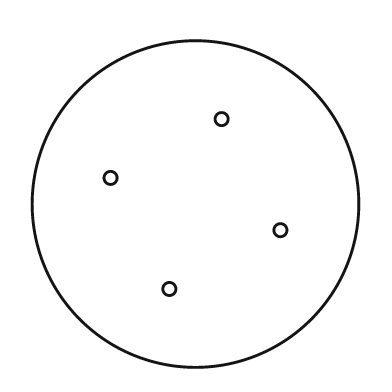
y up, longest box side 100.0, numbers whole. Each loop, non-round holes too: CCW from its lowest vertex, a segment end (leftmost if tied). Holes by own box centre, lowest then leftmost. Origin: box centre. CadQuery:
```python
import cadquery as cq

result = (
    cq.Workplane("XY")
    .moveTo(0.0, 0.0)
    .circle(50.0)
    .moveTo(-8.0, -26.0)
    .circle(2.0)
    .moveTo(26.0, -8.0)
    .circle(2.0)
    .moveTo(-26.0, 8.0)
    .circle(2.0)
    .moveTo(8.0, 26.0)
    .circle(2.0)
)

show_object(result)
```